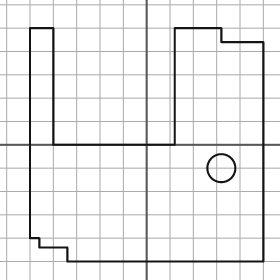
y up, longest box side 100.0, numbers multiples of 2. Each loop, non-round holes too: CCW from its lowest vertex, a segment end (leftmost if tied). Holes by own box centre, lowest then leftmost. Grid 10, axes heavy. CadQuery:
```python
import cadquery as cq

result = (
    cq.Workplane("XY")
    .moveTo(-34.0, -50.0)
    .lineTo(50.0, -50.0)
    .lineTo(50.0, 44.0)
    .lineTo(32.0, 44.0)
    .lineTo(32.0, 50.0)
    .lineTo(12.0, 50.0)
    .lineTo(12.0, 0.0)
    .lineTo(-40.0, 0.0)
    .lineTo(-40.0, 50.0)
    .lineTo(-50.0, 50.0)
    .lineTo(-50.0, -40.0)
    .lineTo(-46.0, -40.0)
    .lineTo(-46.0, -44.0)
    .lineTo(-34.0, -44.0)
    .close()
    .moveTo(32.0, -10.0)
    .circle(6.0)
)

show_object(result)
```